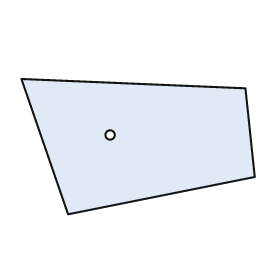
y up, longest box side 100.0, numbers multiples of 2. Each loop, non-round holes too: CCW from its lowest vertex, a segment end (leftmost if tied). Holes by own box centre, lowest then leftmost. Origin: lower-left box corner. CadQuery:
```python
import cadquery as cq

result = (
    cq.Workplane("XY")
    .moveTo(20.0, 0.0)
    .lineTo(100.0, 16.0)
    .lineTo(96.0, 54.0)
    .lineTo(0.0, 58.0)
    .close()
    .moveTo(38.0, 34.0)
    .circle(2.0)
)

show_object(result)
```